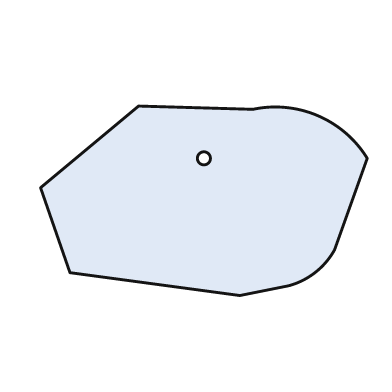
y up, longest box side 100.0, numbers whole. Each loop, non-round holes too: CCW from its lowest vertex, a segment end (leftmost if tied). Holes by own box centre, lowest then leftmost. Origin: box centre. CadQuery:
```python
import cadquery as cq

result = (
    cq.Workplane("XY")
    .moveTo(11.0, -29.0)
    .lineTo(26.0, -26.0)
    .threePointArc((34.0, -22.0), (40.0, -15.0))
    .lineTo(50.0, 13.0)
    .threePointArc((35.0, 26.0), (15.0, 28.0))
    .lineTo(-20.0, 29.0)
    .lineTo(-50.0, 4.0)
    .lineTo(-41.0, -22.0)
    .close()
    .moveTo(0.0, 13.0)
    .circle(2.0)
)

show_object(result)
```